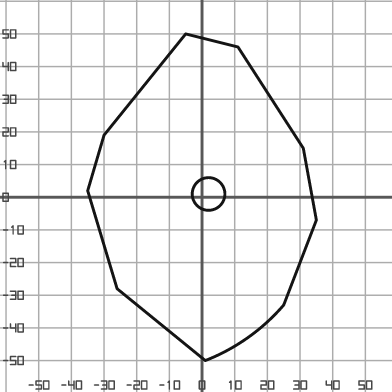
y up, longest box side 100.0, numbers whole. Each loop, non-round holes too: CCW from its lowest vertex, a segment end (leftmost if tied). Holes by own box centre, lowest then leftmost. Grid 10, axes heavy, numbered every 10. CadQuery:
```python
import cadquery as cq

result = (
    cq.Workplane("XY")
    .moveTo(1.0, -50.0)
    .threePointArc((14.0, -43.0), (25.0, -33.0))
    .lineTo(35.0, -7.0)
    .lineTo(31.0, 15.0)
    .lineTo(11.0, 46.0)
    .lineTo(-5.0, 50.0)
    .lineTo(-30.0, 19.0)
    .lineTo(-35.0, 2.0)
    .lineTo(-26.0, -28.0)
    .close()
    .moveTo(2.0, 1.0)
    .circle(5.0)
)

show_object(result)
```